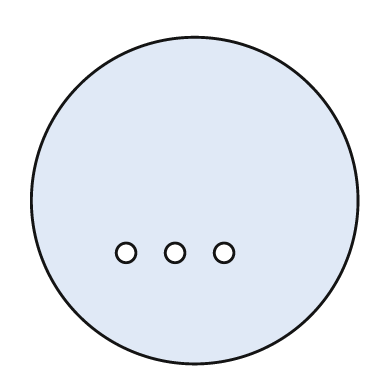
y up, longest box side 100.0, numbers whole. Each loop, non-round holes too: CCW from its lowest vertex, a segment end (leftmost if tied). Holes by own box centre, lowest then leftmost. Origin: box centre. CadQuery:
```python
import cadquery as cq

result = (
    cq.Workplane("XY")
    .moveTo(0.0, 0.0)
    .circle(50.0)
    .moveTo(-21.0, -16.0)
    .circle(3.0)
    .moveTo(-6.0, -16.0)
    .circle(3.0)
    .moveTo(9.0, -16.0)
    .circle(3.0)
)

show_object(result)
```